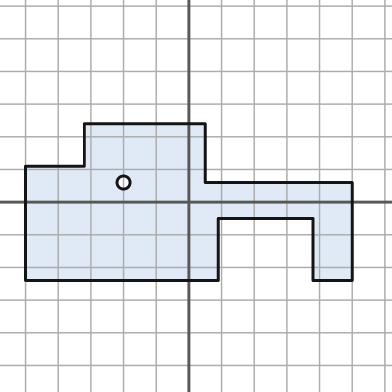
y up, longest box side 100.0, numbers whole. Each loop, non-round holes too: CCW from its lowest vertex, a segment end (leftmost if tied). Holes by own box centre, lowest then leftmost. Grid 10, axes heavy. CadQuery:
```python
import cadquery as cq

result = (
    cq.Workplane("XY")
    .moveTo(-50.0, -24.0)
    .lineTo(9.0, -24.0)
    .lineTo(9.0, -5.0)
    .lineTo(38.0, -5.0)
    .lineTo(38.0, -24.0)
    .lineTo(50.0, -24.0)
    .lineTo(50.0, 6.0)
    .lineTo(5.0, 6.0)
    .lineTo(5.0, 24.0)
    .lineTo(-32.0, 24.0)
    .lineTo(-32.0, 11.0)
    .lineTo(-50.0, 11.0)
    .close()
    .moveTo(-20.0, 6.0)
    .circle(2.0)
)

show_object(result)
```